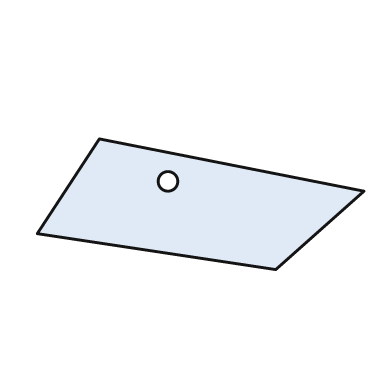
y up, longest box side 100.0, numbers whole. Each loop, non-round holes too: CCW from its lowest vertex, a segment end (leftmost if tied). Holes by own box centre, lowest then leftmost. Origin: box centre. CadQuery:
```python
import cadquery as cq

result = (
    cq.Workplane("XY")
    .moveTo(23.0, -20.0)
    .lineTo(50.0, 4.0)
    .lineTo(-31.0, 20.0)
    .lineTo(-50.0, -9.0)
    .close()
    .moveTo(-10.0, 7.0)
    .circle(3.0)
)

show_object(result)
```